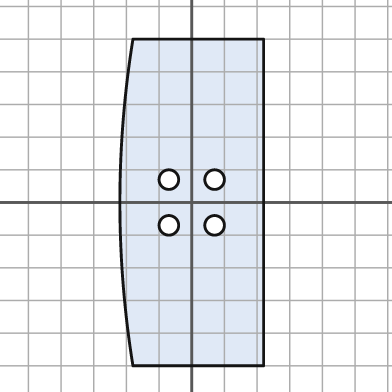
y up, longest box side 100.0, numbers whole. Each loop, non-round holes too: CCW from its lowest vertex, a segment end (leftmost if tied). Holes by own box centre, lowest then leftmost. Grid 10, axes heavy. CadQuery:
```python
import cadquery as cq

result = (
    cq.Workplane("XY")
    .moveTo(-18.0, -50.0)
    .lineTo(22.0, -50.0)
    .lineTo(22.0, 50.0)
    .lineTo(-18.0, 50.0)
    .threePointArc((-22.0, 0.0), (-18.0, -50.0))
    .close()
    .moveTo(-7.0, -7.0)
    .circle(3.0)
    .moveTo(7.0, -7.0)
    .circle(3.0)
    .moveTo(-7.0, 7.0)
    .circle(3.0)
    .moveTo(7.0, 7.0)
    .circle(3.0)
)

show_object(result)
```